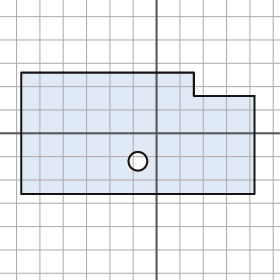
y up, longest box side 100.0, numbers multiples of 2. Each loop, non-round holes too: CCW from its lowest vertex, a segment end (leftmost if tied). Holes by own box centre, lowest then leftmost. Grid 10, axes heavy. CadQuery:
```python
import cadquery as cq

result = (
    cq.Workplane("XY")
    .moveTo(-58.0, -26.0)
    .lineTo(42.0, -26.0)
    .lineTo(42.0, 16.0)
    .lineTo(16.0, 16.0)
    .lineTo(16.0, 26.0)
    .lineTo(-58.0, 26.0)
    .close()
    .moveTo(-8.0, -12.0)
    .circle(4.0)
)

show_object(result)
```